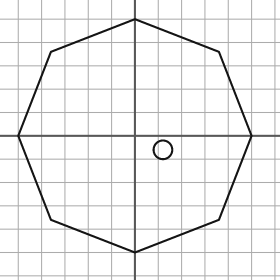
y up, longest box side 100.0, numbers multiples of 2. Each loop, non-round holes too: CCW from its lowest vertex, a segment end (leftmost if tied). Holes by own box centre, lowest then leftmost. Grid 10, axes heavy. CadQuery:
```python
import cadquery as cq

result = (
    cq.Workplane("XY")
    .moveTo(0.0, -50.0)
    .lineTo(36.0, -36.0)
    .lineTo(50.0, 0.0)
    .lineTo(36.0, 36.0)
    .lineTo(0.0, 50.0)
    .lineTo(-36.0, 36.0)
    .lineTo(-50.0, 0.0)
    .lineTo(-36.0, -36.0)
    .close()
    .moveTo(12.0, -6.0)
    .circle(4.0)
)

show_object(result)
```